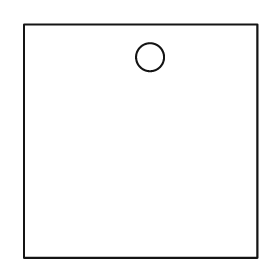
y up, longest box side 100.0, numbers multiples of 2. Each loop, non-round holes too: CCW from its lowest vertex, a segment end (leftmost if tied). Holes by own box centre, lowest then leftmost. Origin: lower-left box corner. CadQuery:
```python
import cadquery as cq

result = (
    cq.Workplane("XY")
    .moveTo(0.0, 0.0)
    .lineTo(100.0, 0.0)
    .lineTo(100.0, 100.0)
    .lineTo(0.0, 100.0)
    .close()
    .moveTo(54.0, 86.0)
    .circle(6.0)
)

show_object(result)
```